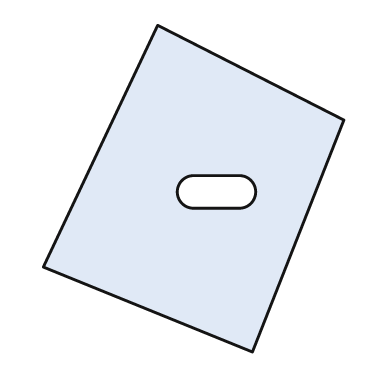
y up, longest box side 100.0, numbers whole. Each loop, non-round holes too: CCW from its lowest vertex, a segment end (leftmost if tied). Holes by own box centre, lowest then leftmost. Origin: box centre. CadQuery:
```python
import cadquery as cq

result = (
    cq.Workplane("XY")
    .moveTo(18.0, -50.0)
    .lineTo(46.0, 21.0)
    .lineTo(-11.0, 50.0)
    .lineTo(-46.0, -24.0)
    .close()
    .moveTo(0.0, -6.0)
    .lineTo(14.0, -6.0)
    .threePointArc((19.0, -1.0), (14.0, 4.0))
    .lineTo(0.0, 4.0)
    .threePointArc((-5.0, -1.0), (0.0, -6.0))
    .close()
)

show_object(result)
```